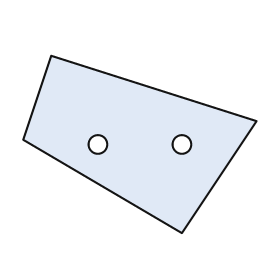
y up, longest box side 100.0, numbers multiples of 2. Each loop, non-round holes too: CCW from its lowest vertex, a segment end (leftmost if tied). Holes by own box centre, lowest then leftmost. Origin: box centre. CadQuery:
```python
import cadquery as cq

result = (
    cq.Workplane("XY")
    .moveTo(18.0, -38.0)
    .lineTo(50.0, 10.0)
    .lineTo(-38.0, 38.0)
    .lineTo(-50.0, 2.0)
    .close()
    .moveTo(-18.0, 0.0)
    .circle(4.0)
    .moveTo(18.0, 0.0)
    .circle(4.0)
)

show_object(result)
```